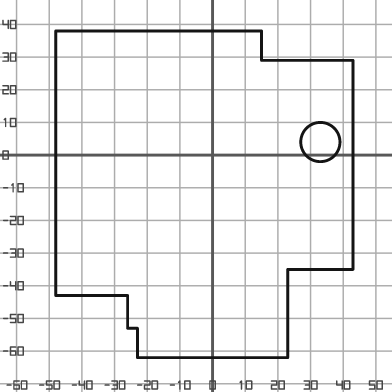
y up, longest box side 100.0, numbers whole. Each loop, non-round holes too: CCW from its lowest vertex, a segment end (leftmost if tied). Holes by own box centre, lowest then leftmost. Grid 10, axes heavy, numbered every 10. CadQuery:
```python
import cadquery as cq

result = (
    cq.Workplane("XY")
    .moveTo(-23.0, -62.0)
    .lineTo(23.0, -62.0)
    .lineTo(23.0, -35.0)
    .lineTo(43.0, -35.0)
    .lineTo(43.0, 29.0)
    .lineTo(15.0, 29.0)
    .lineTo(15.0, 38.0)
    .lineTo(-48.0, 38.0)
    .lineTo(-48.0, -43.0)
    .lineTo(-26.0, -43.0)
    .lineTo(-26.0, -53.0)
    .lineTo(-23.0, -53.0)
    .close()
    .moveTo(33.0, 4.0)
    .circle(6.0)
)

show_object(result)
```